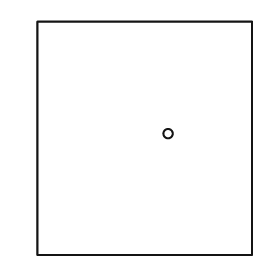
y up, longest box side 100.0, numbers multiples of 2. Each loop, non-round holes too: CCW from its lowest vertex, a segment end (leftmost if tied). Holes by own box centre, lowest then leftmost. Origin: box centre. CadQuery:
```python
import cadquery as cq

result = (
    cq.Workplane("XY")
    .moveTo(-46.0, -50.0)
    .lineTo(46.0, -50.0)
    .lineTo(46.0, 50.0)
    .lineTo(-46.0, 50.0)
    .close()
    .moveTo(10.0, 2.0)
    .circle(2.0)
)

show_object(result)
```